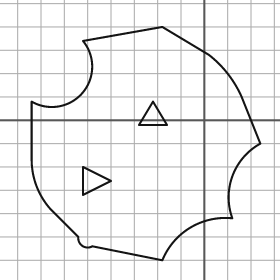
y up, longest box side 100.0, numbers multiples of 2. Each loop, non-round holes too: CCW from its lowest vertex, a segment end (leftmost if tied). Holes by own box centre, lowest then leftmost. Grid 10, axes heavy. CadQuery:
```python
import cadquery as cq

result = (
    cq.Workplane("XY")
    .moveTo(-18.0, -60.0)
    .threePointArc((-6.0, -46.0), (12.0, -42.0))
    .threePointArc((12.0, -24.0), (24.0, -10.0))
    .lineTo(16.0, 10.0)
    .threePointArc((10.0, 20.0), (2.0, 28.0))
    .lineTo(-18.0, 40.0)
    .lineTo(-52.0, 34.0)
    .threePointArc((-52.0, 12.0), (-74.0, 8.0))
    .lineTo(-74.0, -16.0)
    .threePointArc((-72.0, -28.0), (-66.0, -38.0))
    .lineTo(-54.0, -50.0)
    .threePointArc((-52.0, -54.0), (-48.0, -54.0))
    .close()
    .moveTo(-52.0, -32.0)
    .lineTo(-40.0, -26.0)
    .lineTo(-52.0, -20.0)
    .close()
    .moveTo(-28.0, -2.0)
    .lineTo(-16.0, -2.0)
    .lineTo(-22.0, 8.0)
    .close()
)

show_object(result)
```